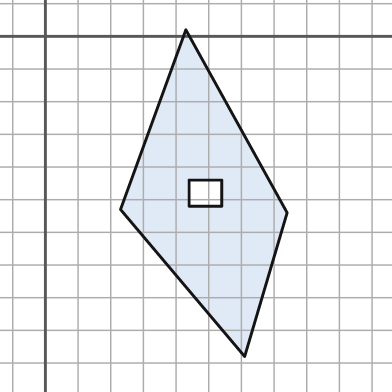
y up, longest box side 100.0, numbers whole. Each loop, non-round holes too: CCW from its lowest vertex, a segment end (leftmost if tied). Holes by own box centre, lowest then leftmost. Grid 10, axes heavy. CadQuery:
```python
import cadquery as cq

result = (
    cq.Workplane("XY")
    .moveTo(61.0, -98.0)
    .lineTo(74.0, -54.0)
    .lineTo(43.0, 2.0)
    .lineTo(23.0, -53.0)
    .close()
    .moveTo(44.0, -52.0)
    .lineTo(54.0, -52.0)
    .lineTo(54.0, -44.0)
    .lineTo(44.0, -44.0)
    .close()
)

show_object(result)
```